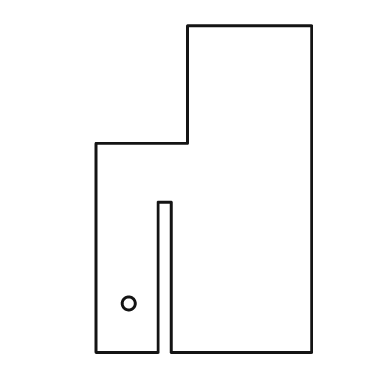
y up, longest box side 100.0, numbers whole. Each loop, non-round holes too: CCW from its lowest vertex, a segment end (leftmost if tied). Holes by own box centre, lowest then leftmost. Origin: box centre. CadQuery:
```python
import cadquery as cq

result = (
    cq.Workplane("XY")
    .moveTo(-33.0, -50.0)
    .lineTo(-14.0, -50.0)
    .lineTo(-14.0, -4.0)
    .lineTo(-10.0, -4.0)
    .lineTo(-10.0, -50.0)
    .lineTo(33.0, -50.0)
    .lineTo(33.0, 50.0)
    .lineTo(-5.0, 50.0)
    .lineTo(-5.0, 14.0)
    .lineTo(-33.0, 14.0)
    .close()
    .moveTo(-23.0, -35.0)
    .circle(2.0)
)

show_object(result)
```